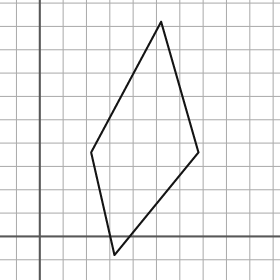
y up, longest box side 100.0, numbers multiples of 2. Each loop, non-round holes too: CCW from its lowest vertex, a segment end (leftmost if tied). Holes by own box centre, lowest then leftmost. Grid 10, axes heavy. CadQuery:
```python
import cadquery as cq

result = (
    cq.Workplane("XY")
    .moveTo(32.0, -8.0)
    .lineTo(68.0, 36.0)
    .lineTo(52.0, 92.0)
    .lineTo(22.0, 36.0)
    .close()
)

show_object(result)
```